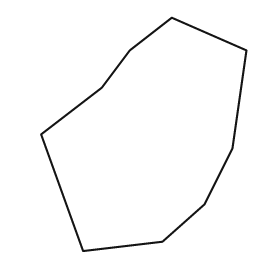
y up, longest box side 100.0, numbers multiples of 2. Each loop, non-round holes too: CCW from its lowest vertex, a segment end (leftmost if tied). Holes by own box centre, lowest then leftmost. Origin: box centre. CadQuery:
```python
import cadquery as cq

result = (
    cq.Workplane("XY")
    .moveTo(-26.0, -50.0)
    .lineTo(8.0, -46.0)
    .lineTo(26.0, -30.0)
    .lineTo(38.0, -6.0)
    .lineTo(44.0, 36.0)
    .lineTo(12.0, 50.0)
    .lineTo(-6.0, 36.0)
    .lineTo(-18.0, 20.0)
    .lineTo(-44.0, 0.0)
    .close()
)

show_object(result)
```